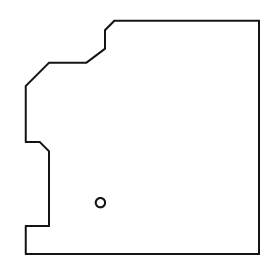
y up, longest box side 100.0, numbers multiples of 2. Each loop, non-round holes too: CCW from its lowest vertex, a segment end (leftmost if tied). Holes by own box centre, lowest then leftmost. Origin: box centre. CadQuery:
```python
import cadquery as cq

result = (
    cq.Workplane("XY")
    .moveTo(-50.0, -50.0)
    .lineTo(50.0, -50.0)
    .lineTo(50.0, 50.0)
    .lineTo(-12.0, 50.0)
    .lineTo(-16.0, 46.0)
    .lineTo(-16.0, 38.0)
    .lineTo(-24.0, 32.0)
    .lineTo(-40.0, 32.0)
    .lineTo(-50.0, 22.0)
    .lineTo(-50.0, -2.0)
    .lineTo(-44.0, -2.0)
    .lineTo(-40.0, -6.0)
    .lineTo(-40.0, -38.0)
    .lineTo(-50.0, -38.0)
    .close()
    .moveTo(-18.0, -28.0)
    .circle(2.0)
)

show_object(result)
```